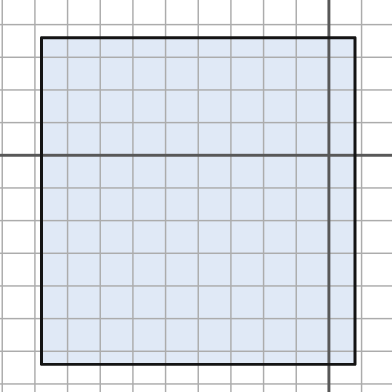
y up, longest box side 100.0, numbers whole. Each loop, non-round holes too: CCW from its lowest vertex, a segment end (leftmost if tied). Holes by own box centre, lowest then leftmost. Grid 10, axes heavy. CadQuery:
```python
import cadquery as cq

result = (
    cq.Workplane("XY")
    .moveTo(-88.0, -64.0)
    .lineTo(8.0, -64.0)
    .lineTo(8.0, 36.0)
    .lineTo(-88.0, 36.0)
    .close()
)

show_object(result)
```